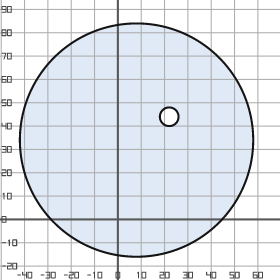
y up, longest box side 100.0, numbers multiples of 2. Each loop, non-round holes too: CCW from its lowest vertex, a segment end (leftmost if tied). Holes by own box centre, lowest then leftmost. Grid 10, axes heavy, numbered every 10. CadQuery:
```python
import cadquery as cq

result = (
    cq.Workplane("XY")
    .moveTo(8.0, 34.0)
    .circle(50.0)
    .moveTo(22.0, 44.0)
    .circle(4.0)
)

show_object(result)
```